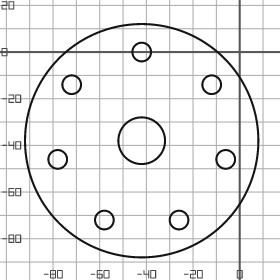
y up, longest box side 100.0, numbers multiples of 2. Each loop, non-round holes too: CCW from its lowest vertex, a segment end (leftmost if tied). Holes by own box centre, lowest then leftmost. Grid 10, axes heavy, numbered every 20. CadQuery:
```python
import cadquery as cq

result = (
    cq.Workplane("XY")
    .moveTo(-42.0, -38.0)
    .circle(50.0)
    .moveTo(-58.0, -72.0)
    .circle(4.0)
    .moveTo(-26.0, -72.0)
    .circle(4.0)
    .moveTo(-78.0, -46.0)
    .circle(4.0)
    .moveTo(-6.0, -46.0)
    .circle(4.0)
    .moveTo(-42.0, -38.0)
    .circle(10.0)
    .moveTo(-72.0, -14.0)
    .circle(4.0)
    .moveTo(-12.0, -14.0)
    .circle(4.0)
    .moveTo(-42.0, 0.0)
    .circle(4.0)
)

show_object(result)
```